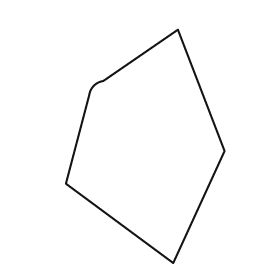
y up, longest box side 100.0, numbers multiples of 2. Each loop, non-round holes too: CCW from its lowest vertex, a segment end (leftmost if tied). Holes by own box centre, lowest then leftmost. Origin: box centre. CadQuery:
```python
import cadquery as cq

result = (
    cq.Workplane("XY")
    .moveTo(12.0, -50.0)
    .lineTo(34.0, -2.0)
    .lineTo(14.0, 50.0)
    .lineTo(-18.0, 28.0)
    .threePointArc((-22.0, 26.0), (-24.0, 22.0))
    .lineTo(-34.0, -16.0)
    .close()
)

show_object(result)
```